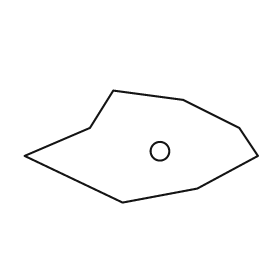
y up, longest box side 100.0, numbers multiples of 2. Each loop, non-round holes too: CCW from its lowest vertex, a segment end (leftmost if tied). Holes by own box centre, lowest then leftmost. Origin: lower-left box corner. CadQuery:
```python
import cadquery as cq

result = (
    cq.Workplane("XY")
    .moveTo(42.0, 0.0)
    .lineTo(74.0, 6.0)
    .lineTo(100.0, 20.0)
    .lineTo(92.0, 32.0)
    .lineTo(68.0, 44.0)
    .lineTo(38.0, 48.0)
    .lineTo(28.0, 32.0)
    .lineTo(0.0, 20.0)
    .close()
    .moveTo(58.0, 22.0)
    .circle(4.0)
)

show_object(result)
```